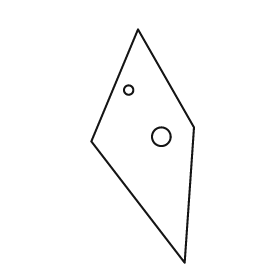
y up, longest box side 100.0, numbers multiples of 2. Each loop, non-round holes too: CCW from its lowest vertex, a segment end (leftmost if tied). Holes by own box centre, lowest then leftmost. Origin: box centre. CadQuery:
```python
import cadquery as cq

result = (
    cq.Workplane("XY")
    .moveTo(18.0, -50.0)
    .lineTo(22.0, 8.0)
    .lineTo(-2.0, 50.0)
    .lineTo(-22.0, 2.0)
    .close()
    .moveTo(8.0, 4.0)
    .circle(4.0)
    .moveTo(-6.0, 24.0)
    .circle(2.0)
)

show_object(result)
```